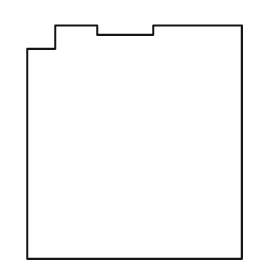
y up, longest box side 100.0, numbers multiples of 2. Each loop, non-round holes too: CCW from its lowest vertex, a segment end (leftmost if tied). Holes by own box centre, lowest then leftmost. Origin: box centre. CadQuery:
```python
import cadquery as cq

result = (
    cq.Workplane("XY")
    .moveTo(-46.0, -50.0)
    .lineTo(46.0, -50.0)
    .lineTo(46.0, 50.0)
    .lineTo(8.0, 50.0)
    .lineTo(8.0, 46.0)
    .lineTo(-16.0, 46.0)
    .lineTo(-16.0, 50.0)
    .lineTo(-34.0, 50.0)
    .lineTo(-34.0, 40.0)
    .lineTo(-46.0, 40.0)
    .close()
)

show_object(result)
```